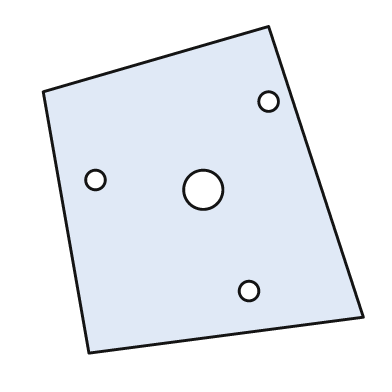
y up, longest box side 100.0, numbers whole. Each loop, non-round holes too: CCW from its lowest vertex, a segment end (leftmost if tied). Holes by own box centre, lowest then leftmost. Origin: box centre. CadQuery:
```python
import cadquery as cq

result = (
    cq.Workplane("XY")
    .moveTo(-35.0, -50.0)
    .lineTo(49.0, -39.0)
    .lineTo(20.0, 50.0)
    .lineTo(-49.0, 30.0)
    .close()
    .moveTo(14.0, -31.0)
    .circle(3.0)
    .moveTo(0.0, 0.0)
    .circle(6.0)
    .moveTo(-33.0, 3.0)
    .circle(3.0)
    .moveTo(20.0, 27.0)
    .circle(3.0)
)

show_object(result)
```